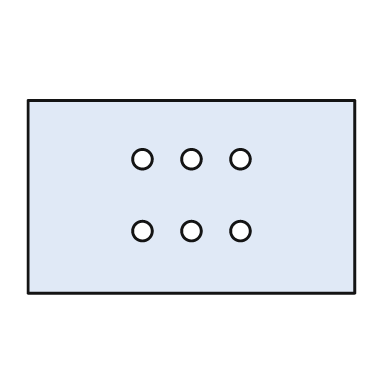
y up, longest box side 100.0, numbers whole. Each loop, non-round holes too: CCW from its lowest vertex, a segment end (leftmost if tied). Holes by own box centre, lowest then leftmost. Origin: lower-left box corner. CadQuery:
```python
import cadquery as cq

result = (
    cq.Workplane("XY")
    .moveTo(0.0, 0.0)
    .lineTo(100.0, 0.0)
    .lineTo(100.0, 59.0)
    .lineTo(0.0, 59.0)
    .close()
    .moveTo(35.0, 19.0)
    .circle(3.0)
    .moveTo(50.0, 19.0)
    .circle(3.0)
    .moveTo(65.0, 19.0)
    .circle(3.0)
    .moveTo(35.0, 41.0)
    .circle(3.0)
    .moveTo(50.0, 41.0)
    .circle(3.0)
    .moveTo(65.0, 41.0)
    .circle(3.0)
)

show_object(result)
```